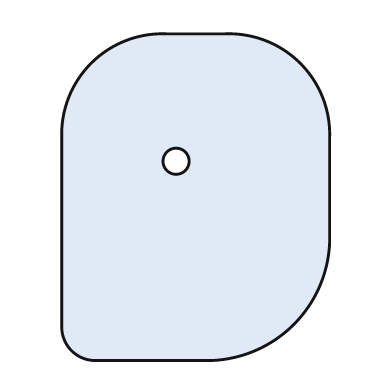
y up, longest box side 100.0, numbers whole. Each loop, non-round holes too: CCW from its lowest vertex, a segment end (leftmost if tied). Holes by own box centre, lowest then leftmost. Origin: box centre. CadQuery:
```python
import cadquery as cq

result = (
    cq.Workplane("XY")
    .moveTo(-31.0, -50.0)
    .lineTo(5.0, -50.0)
    .threePointArc((30.0, -39.0), (41.0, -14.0))
    .lineTo(41.0, 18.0)
    .threePointArc((32.0, 41.0), (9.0, 50.0))
    .lineTo(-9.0, 50.0)
    .threePointArc((-32.0, 41.0), (-41.0, 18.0))
    .lineTo(-41.0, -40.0)
    .threePointArc((-38.0, -47.0), (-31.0, -50.0))
    .close()
    .moveTo(-6.0, 11.0)
    .circle(4.0)
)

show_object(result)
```